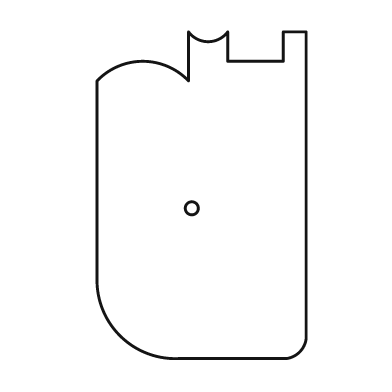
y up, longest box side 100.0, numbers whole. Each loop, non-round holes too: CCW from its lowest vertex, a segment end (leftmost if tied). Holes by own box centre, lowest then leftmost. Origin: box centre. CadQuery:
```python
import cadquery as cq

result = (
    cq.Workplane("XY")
    .moveTo(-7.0, -50.0)
    .lineTo(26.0, -50.0)
    .threePointArc((30.0, -48.0), (32.0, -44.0))
    .lineTo(32.0, 50.0)
    .lineTo(25.0, 50.0)
    .lineTo(25.0, 41.0)
    .lineTo(8.0, 41.0)
    .lineTo(8.0, 50.0)
    .threePointArc((2.0, 47.0), (-4.0, 50.0))
    .lineTo(-4.0, 35.0)
    .threePointArc((-18.0, 41.0), (-32.0, 35.0))
    .lineTo(-32.0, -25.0)
    .threePointArc((-25.0, -43.0), (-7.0, -50.0))
    .close()
    .moveTo(-3.0, -4.0)
    .circle(2.0)
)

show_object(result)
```